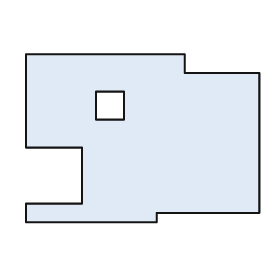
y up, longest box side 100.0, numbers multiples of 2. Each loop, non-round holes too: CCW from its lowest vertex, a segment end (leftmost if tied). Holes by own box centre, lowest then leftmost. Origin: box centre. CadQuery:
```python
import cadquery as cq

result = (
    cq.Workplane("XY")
    .moveTo(-50.0, -36.0)
    .lineTo(6.0, -36.0)
    .lineTo(6.0, -32.0)
    .lineTo(50.0, -32.0)
    .lineTo(50.0, 28.0)
    .lineTo(18.0, 28.0)
    .lineTo(18.0, 36.0)
    .lineTo(-50.0, 36.0)
    .lineTo(-50.0, -4.0)
    .lineTo(-26.0, -4.0)
    .lineTo(-26.0, -28.0)
    .lineTo(-50.0, -28.0)
    .close()
    .moveTo(-20.0, 8.0)
    .lineTo(-8.0, 8.0)
    .lineTo(-8.0, 20.0)
    .lineTo(-20.0, 20.0)
    .close()
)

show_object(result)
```